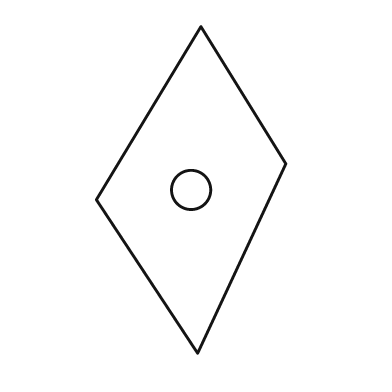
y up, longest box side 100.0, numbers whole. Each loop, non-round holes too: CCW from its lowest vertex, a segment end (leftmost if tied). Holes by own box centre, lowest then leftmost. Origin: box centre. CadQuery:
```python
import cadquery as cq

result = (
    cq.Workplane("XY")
    .moveTo(2.0, -50.0)
    .lineTo(29.0, 8.0)
    .lineTo(3.0, 50.0)
    .lineTo(-29.0, -3.0)
    .close()
    .moveTo(0.0, 0.0)
    .circle(6.0)
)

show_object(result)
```